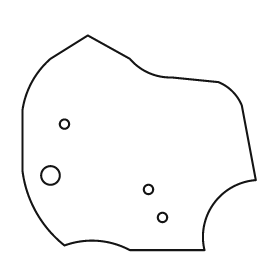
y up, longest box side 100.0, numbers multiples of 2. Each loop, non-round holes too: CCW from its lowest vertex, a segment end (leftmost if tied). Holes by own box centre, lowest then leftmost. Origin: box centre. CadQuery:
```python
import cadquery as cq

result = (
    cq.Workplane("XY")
    .moveTo(-4.0, -46.0)
    .lineTo(28.0, -46.0)
    .threePointArc((32.0, -26.0), (50.0, -16.0))
    .lineTo(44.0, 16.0)
    .threePointArc((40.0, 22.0), (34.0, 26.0))
    .lineTo(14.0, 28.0)
    .threePointArc((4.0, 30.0), (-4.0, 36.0))
    .lineTo(-22.0, 46.0)
    .lineTo(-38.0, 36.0)
    .threePointArc((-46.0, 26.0), (-50.0, 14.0))
    .lineTo(-50.0, -12.0)
    .threePointArc((-44.0, -30.0), (-32.0, -44.0))
    .threePointArc((-18.0, -42.0), (-4.0, -46.0))
    .close()
    .moveTo(10.0, -32.0)
    .circle(2.0)
    .moveTo(4.0, -20.0)
    .circle(2.0)
    .moveTo(-38.0, -14.0)
    .circle(4.0)
    .moveTo(-32.0, 8.0)
    .circle(2.0)
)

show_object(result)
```